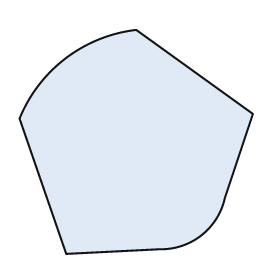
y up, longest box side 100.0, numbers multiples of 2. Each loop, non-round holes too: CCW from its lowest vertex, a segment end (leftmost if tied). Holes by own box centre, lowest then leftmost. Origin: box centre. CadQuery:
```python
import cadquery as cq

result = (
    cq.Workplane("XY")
    .moveTo(-30.0, -48.0)
    .lineTo(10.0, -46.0)
    .threePointArc((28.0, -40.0), (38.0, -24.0))
    .lineTo(50.0, 12.0)
    .lineTo(0.0, 48.0)
    .threePointArc((-30.0, 36.0), (-50.0, 10.0))
    .close()
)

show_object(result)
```